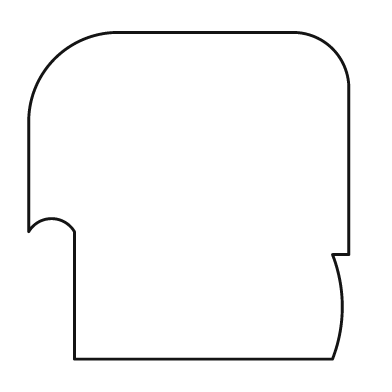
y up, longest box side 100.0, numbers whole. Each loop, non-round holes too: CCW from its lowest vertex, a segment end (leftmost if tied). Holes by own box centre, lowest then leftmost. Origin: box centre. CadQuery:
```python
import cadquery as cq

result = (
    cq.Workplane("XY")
    .moveTo(-35.0, -50.0)
    .lineTo(44.0, -50.0)
    .threePointArc((47.0, -34.0), (44.0, -18.0))
    .lineTo(49.0, -18.0)
    .lineTo(49.0, 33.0)
    .threePointArc((44.0, 45.0), (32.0, 50.0))
    .lineTo(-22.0, 50.0)
    .threePointArc((-41.0, 42.0), (-49.0, 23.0))
    .lineTo(-49.0, -11.0)
    .threePointArc((-42.0, -7.0), (-35.0, -11.0))
    .close()
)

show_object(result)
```